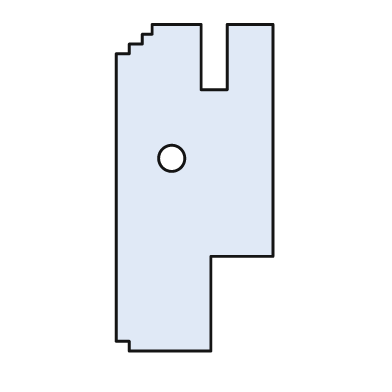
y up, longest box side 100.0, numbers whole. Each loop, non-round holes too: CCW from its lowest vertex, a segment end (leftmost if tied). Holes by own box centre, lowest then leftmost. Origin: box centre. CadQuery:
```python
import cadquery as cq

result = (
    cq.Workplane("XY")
    .moveTo(-20.0, -50.0)
    .lineTo(5.0, -50.0)
    .lineTo(5.0, -21.0)
    .lineTo(24.0, -21.0)
    .lineTo(24.0, 50.0)
    .lineTo(10.0, 50.0)
    .lineTo(10.0, 30.0)
    .lineTo(2.0, 30.0)
    .lineTo(2.0, 50.0)
    .lineTo(-13.0, 50.0)
    .lineTo(-13.0, 47.0)
    .lineTo(-16.0, 47.0)
    .lineTo(-16.0, 44.0)
    .lineTo(-20.0, 44.0)
    .lineTo(-20.0, 41.0)
    .lineTo(-24.0, 41.0)
    .lineTo(-24.0, -47.0)
    .lineTo(-20.0, -47.0)
    .close()
    .moveTo(-7.0, 9.0)
    .circle(4.0)
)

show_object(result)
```